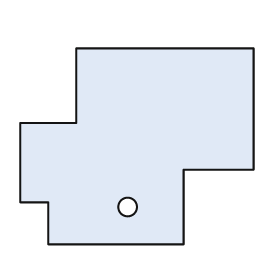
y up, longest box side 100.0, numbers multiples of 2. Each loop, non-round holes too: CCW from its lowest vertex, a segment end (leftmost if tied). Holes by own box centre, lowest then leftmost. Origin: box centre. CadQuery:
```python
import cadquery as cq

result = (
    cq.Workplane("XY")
    .moveTo(-38.0, -42.0)
    .lineTo(20.0, -42.0)
    .lineTo(20.0, -10.0)
    .lineTo(50.0, -10.0)
    .lineTo(50.0, 42.0)
    .lineTo(-26.0, 42.0)
    .lineTo(-26.0, 10.0)
    .lineTo(-50.0, 10.0)
    .lineTo(-50.0, -24.0)
    .lineTo(-38.0, -24.0)
    .close()
    .moveTo(-4.0, -26.0)
    .circle(4.0)
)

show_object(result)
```